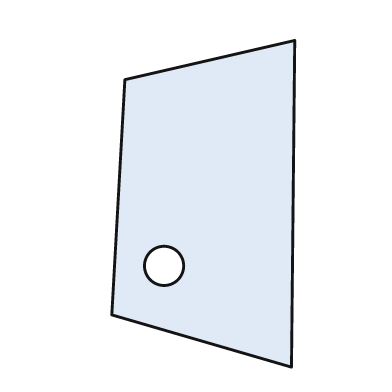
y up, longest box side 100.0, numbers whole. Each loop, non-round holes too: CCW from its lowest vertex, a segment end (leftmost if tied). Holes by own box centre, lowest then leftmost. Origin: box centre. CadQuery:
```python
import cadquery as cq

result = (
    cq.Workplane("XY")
    .moveTo(27.0, -50.0)
    .lineTo(28.0, 50.0)
    .lineTo(-24.0, 38.0)
    .lineTo(-28.0, -34.0)
    .close()
    .moveTo(-12.0, -19.0)
    .circle(6.0)
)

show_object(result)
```